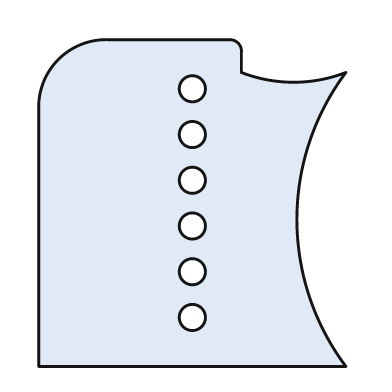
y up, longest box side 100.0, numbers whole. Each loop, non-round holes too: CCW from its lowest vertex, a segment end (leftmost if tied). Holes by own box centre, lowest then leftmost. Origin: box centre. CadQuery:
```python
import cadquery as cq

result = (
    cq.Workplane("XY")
    .moveTo(-47.0, -50.0)
    .lineTo(47.0, -50.0)
    .threePointArc((32.0, -5.0), (47.0, 40.0))
    .threePointArc((31.0, 37.0), (15.0, 40.0))
    .lineTo(15.0, 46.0)
    .threePointArc((14.0, 49.0), (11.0, 50.0))
    .lineTo(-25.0, 50.0)
    .threePointArc((-41.0, 44.0), (-47.0, 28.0))
    .close()
    .moveTo(0.0, -35.0)
    .circle(4.0)
    .moveTo(0.0, -21.0)
    .circle(4.0)
    .moveTo(0.0, -7.0)
    .circle(4.0)
    .moveTo(0.0, 7.0)
    .circle(4.0)
    .moveTo(0.0, 21.0)
    .circle(4.0)
    .moveTo(0.0, 35.0)
    .circle(4.0)
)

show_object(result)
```